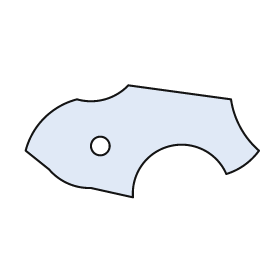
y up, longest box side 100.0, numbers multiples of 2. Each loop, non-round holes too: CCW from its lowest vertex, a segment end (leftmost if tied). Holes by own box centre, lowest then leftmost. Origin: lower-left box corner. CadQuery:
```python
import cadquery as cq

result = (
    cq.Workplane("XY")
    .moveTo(46.0, 0.0)
    .threePointArc((62.0, 22.0), (86.0, 10.0))
    .threePointArc((94.0, 14.0), (100.0, 20.0))
    .threePointArc((92.0, 30.0), (88.0, 42.0))
    .lineTo(44.0, 48.0)
    .threePointArc((34.0, 42.0), (22.0, 42.0))
    .threePointArc((8.0, 34.0), (0.0, 20.0))
    .lineTo(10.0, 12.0)
    .threePointArc((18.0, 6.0), (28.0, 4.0))
    .close()
    .moveTo(32.0, 22.0)
    .circle(4.0)
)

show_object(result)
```